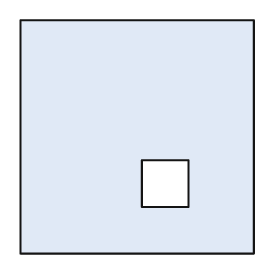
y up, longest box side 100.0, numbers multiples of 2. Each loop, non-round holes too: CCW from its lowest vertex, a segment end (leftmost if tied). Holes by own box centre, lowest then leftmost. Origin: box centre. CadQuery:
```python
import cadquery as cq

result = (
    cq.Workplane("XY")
    .moveTo(-50.0, -50.0)
    .lineTo(50.0, -50.0)
    .lineTo(50.0, 50.0)
    .lineTo(-50.0, 50.0)
    .close()
    .moveTo(2.0, -30.0)
    .lineTo(22.0, -30.0)
    .lineTo(22.0, -10.0)
    .lineTo(2.0, -10.0)
    .close()
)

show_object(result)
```